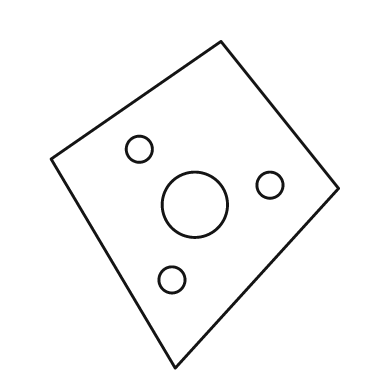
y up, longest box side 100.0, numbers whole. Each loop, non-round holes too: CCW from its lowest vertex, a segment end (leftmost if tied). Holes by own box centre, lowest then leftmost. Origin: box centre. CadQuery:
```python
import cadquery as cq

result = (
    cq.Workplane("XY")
    .moveTo(-6.0, -50.0)
    .lineTo(44.0, 5.0)
    .lineTo(8.0, 50.0)
    .lineTo(-44.0, 14.0)
    .close()
    .moveTo(-7.0, -23.0)
    .circle(4.0)
    .moveTo(0.0, 0.0)
    .circle(10.0)
    .moveTo(23.0, 6.0)
    .circle(4.0)
    .moveTo(-17.0, 17.0)
    .circle(4.0)
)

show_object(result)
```